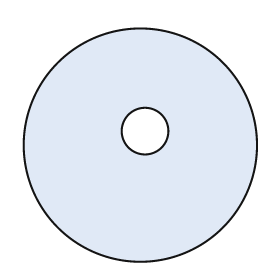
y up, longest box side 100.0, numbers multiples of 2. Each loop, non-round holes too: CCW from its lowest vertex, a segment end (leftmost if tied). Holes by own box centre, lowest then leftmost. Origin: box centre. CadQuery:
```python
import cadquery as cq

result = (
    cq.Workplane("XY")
    .moveTo(0.0, 0.0)
    .circle(50.0)
    .moveTo(2.0, 6.0)
    .circle(10.0)
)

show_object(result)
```